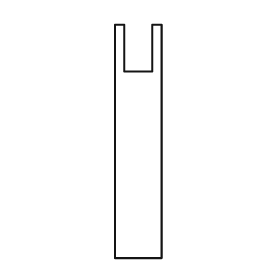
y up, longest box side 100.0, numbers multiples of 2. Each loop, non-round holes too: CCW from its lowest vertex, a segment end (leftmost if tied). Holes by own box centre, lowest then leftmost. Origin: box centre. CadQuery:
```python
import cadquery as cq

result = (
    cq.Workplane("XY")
    .moveTo(-10.0, -50.0)
    .lineTo(10.0, -50.0)
    .lineTo(10.0, 50.0)
    .lineTo(6.0, 50.0)
    .lineTo(6.0, 30.0)
    .lineTo(-6.0, 30.0)
    .lineTo(-6.0, 50.0)
    .lineTo(-10.0, 50.0)
    .close()
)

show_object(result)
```